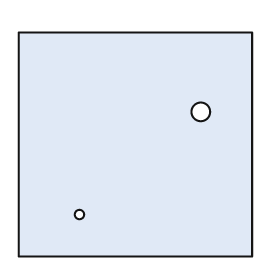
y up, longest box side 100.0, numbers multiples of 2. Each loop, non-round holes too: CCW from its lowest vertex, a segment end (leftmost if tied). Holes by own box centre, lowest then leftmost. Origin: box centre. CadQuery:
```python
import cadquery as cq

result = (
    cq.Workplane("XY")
    .moveTo(-50.0, -48.0)
    .lineTo(50.0, -48.0)
    .lineTo(50.0, 48.0)
    .lineTo(-50.0, 48.0)
    .close()
    .moveTo(-24.0, -30.0)
    .circle(2.0)
    .moveTo(28.0, 14.0)
    .circle(4.0)
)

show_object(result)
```